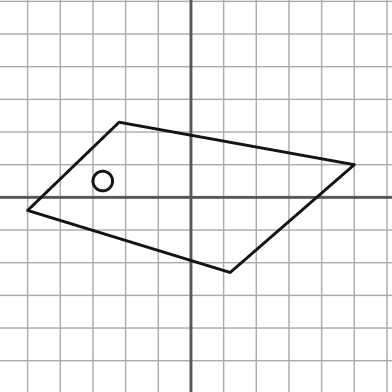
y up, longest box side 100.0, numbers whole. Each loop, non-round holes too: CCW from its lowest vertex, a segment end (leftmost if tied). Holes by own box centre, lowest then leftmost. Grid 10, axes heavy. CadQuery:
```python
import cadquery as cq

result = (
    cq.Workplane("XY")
    .moveTo(12.0, -23.0)
    .lineTo(50.0, 10.0)
    .lineTo(-22.0, 23.0)
    .lineTo(-50.0, -4.0)
    .close()
    .moveTo(-27.0, 5.0)
    .circle(3.0)
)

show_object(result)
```